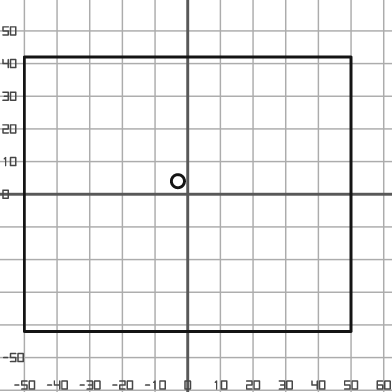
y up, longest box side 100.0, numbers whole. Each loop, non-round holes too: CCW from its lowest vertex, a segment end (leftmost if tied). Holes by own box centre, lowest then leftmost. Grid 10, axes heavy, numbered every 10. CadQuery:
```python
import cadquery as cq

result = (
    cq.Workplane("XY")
    .moveTo(-50.0, -42.0)
    .lineTo(50.0, -42.0)
    .lineTo(50.0, 42.0)
    .lineTo(-50.0, 42.0)
    .close()
    .moveTo(-3.0, 4.0)
    .circle(2.0)
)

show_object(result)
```